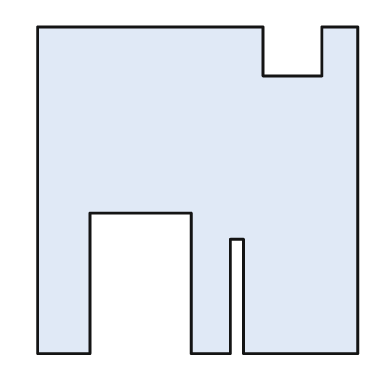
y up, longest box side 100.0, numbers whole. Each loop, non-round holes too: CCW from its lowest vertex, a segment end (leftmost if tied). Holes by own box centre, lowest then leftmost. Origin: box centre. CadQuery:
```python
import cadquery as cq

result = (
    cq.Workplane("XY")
    .moveTo(-49.0, -50.0)
    .lineTo(-33.0, -50.0)
    .lineTo(-33.0, -7.0)
    .lineTo(-2.0, -7.0)
    .lineTo(-2.0, -50.0)
    .lineTo(10.0, -50.0)
    .lineTo(10.0, -15.0)
    .lineTo(14.0, -15.0)
    .lineTo(14.0, -50.0)
    .lineTo(49.0, -50.0)
    .lineTo(49.0, 50.0)
    .lineTo(38.0, 50.0)
    .lineTo(38.0, 35.0)
    .lineTo(20.0, 35.0)
    .lineTo(20.0, 50.0)
    .lineTo(-49.0, 50.0)
    .close()
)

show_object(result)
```